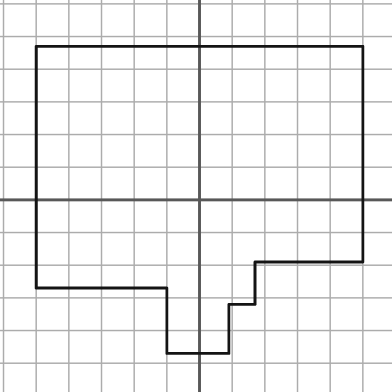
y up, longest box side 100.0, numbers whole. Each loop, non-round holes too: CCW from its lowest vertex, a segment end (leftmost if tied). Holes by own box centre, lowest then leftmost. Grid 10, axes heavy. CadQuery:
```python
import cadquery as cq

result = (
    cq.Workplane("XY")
    .moveTo(-10.0, -47.0)
    .lineTo(9.0, -47.0)
    .lineTo(9.0, -32.0)
    .lineTo(17.0, -32.0)
    .lineTo(17.0, -19.0)
    .lineTo(50.0, -19.0)
    .lineTo(50.0, 47.0)
    .lineTo(-50.0, 47.0)
    .lineTo(-50.0, -27.0)
    .lineTo(-10.0, -27.0)
    .close()
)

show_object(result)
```